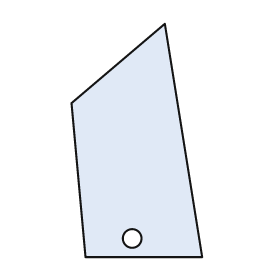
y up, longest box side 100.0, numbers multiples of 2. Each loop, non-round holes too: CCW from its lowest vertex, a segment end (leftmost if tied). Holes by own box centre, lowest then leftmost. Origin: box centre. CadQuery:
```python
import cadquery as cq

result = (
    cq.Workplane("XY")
    .moveTo(-22.0, -50.0)
    .lineTo(28.0, -50.0)
    .lineTo(12.0, 50.0)
    .lineTo(-28.0, 16.0)
    .close()
    .moveTo(-2.0, -42.0)
    .circle(4.0)
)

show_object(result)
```